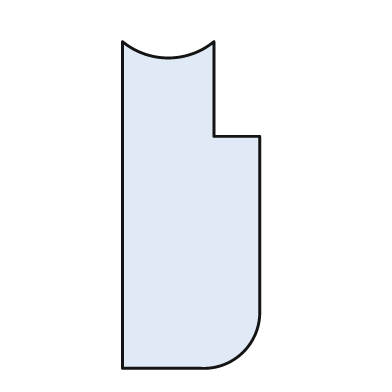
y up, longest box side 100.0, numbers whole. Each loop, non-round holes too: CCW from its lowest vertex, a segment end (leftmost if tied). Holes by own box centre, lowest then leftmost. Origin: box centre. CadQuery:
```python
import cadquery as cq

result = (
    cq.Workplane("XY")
    .moveTo(-21.0, -50.0)
    .lineTo(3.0, -50.0)
    .threePointArc((16.0, -45.0), (21.0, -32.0))
    .lineTo(21.0, 21.0)
    .lineTo(7.0, 21.0)
    .lineTo(7.0, 50.0)
    .threePointArc((-7.0, 45.0), (-21.0, 50.0))
    .close()
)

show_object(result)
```